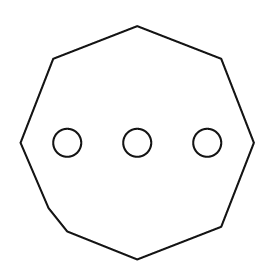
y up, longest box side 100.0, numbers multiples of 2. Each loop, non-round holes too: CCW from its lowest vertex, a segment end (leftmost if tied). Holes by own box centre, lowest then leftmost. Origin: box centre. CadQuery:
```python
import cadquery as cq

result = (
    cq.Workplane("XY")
    .moveTo(0.0, -50.0)
    .lineTo(36.0, -36.0)
    .lineTo(50.0, 0.0)
    .lineTo(36.0, 36.0)
    .lineTo(0.0, 50.0)
    .lineTo(-36.0, 36.0)
    .lineTo(-50.0, 0.0)
    .lineTo(-38.0, -28.0)
    .lineTo(-30.0, -38.0)
    .close()
    .moveTo(-30.0, 0.0)
    .circle(6.0)
    .moveTo(0.0, 0.0)
    .circle(6.0)
    .moveTo(30.0, 0.0)
    .circle(6.0)
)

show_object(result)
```